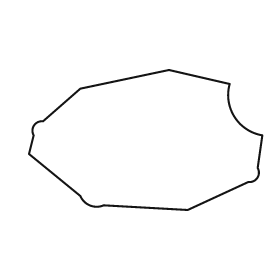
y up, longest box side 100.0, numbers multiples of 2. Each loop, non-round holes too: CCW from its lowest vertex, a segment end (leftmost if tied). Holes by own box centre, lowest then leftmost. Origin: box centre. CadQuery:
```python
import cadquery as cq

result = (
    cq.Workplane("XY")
    .moveTo(18.0, -30.0)
    .lineTo(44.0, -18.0)
    .threePointArc((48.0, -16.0), (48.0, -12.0))
    .lineTo(50.0, 2.0)
    .threePointArc((38.0, 10.0), (36.0, 24.0))
    .lineTo(10.0, 30.0)
    .lineTo(-28.0, 22.0)
    .lineTo(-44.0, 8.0)
    .threePointArc((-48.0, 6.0), (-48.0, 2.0))
    .lineTo(-50.0, -6.0)
    .lineTo(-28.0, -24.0)
    .threePointArc((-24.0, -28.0), (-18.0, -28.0))
    .close()
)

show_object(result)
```